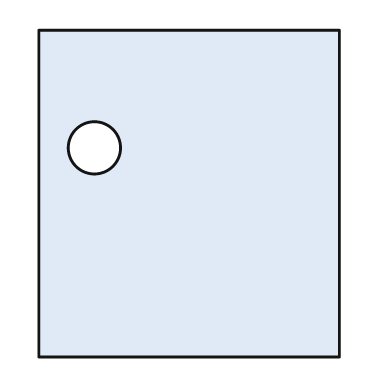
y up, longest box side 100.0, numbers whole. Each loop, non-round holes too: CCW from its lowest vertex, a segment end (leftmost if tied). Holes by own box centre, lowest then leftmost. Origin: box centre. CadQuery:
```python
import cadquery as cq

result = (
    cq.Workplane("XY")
    .moveTo(-46.0, -50.0)
    .lineTo(46.0, -50.0)
    .lineTo(46.0, 50.0)
    .lineTo(-46.0, 50.0)
    .close()
    .moveTo(-29.0, 14.0)
    .circle(8.0)
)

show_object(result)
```